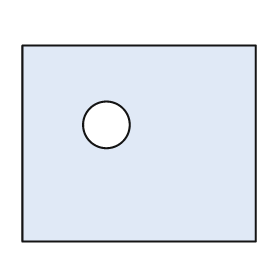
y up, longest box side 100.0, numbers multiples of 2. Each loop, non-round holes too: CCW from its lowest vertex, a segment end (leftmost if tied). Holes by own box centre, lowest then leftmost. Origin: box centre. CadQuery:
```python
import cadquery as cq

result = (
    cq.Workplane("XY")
    .moveTo(-50.0, -42.0)
    .lineTo(50.0, -42.0)
    .lineTo(50.0, 42.0)
    .lineTo(-50.0, 42.0)
    .close()
    .moveTo(-14.0, 8.0)
    .circle(10.0)
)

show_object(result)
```